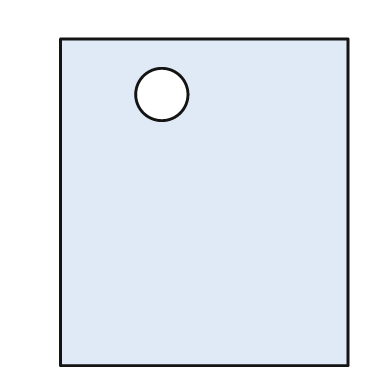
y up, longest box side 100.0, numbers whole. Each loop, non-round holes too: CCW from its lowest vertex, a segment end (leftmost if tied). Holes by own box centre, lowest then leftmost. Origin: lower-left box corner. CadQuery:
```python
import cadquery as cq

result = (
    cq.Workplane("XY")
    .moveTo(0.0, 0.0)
    .lineTo(88.0, 0.0)
    .lineTo(88.0, 100.0)
    .lineTo(0.0, 100.0)
    .close()
    .moveTo(31.0, 83.0)
    .circle(8.0)
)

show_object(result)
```